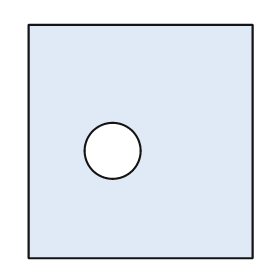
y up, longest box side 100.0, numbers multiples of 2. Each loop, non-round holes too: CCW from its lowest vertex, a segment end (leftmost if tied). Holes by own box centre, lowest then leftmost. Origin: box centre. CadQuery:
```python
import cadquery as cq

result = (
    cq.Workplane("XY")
    .moveTo(-48.0, -50.0)
    .lineTo(48.0, -50.0)
    .lineTo(48.0, 50.0)
    .lineTo(-48.0, 50.0)
    .close()
    .moveTo(-12.0, -4.0)
    .circle(12.0)
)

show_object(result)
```